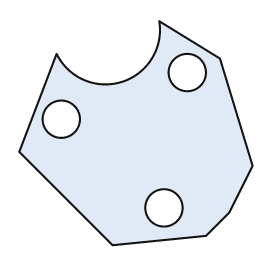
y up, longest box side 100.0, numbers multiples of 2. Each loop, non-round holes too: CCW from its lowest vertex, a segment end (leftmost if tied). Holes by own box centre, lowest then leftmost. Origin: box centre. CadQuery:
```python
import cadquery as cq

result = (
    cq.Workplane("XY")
    .moveTo(-10.0, -48.0)
    .lineTo(30.0, -44.0)
    .lineTo(40.0, -34.0)
    .lineTo(50.0, -14.0)
    .lineTo(36.0, 32.0)
    .lineTo(10.0, 48.0)
    .threePointArc((-6.0, 22.0), (-34.0, 34.0))
    .lineTo(-50.0, -8.0)
    .close()
    .moveTo(12.0, -32.0)
    .circle(8.0)
    .moveTo(-32.0, 6.0)
    .circle(8.0)
    .moveTo(22.0, 26.0)
    .circle(8.0)
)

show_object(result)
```